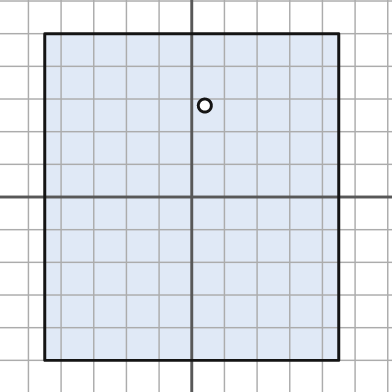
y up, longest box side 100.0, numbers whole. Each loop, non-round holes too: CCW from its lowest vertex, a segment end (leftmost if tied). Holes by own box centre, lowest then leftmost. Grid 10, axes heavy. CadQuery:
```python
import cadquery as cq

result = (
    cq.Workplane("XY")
    .moveTo(-45.0, -50.0)
    .lineTo(45.0, -50.0)
    .lineTo(45.0, 50.0)
    .lineTo(-45.0, 50.0)
    .close()
    .moveTo(4.0, 28.0)
    .circle(2.0)
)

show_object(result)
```